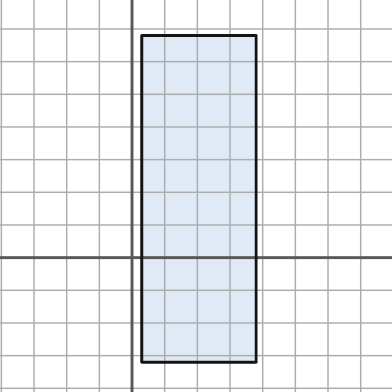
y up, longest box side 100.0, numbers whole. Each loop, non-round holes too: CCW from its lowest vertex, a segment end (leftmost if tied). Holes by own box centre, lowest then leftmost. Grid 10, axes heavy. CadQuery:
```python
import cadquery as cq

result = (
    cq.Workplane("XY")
    .moveTo(3.0, -32.0)
    .lineTo(38.0, -32.0)
    .lineTo(38.0, 68.0)
    .lineTo(3.0, 68.0)
    .close()
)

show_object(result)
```